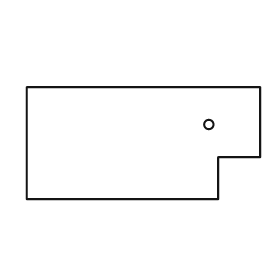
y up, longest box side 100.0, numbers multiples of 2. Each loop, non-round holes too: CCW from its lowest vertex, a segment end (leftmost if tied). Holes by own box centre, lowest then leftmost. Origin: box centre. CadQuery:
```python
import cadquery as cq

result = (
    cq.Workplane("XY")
    .moveTo(-50.0, -24.0)
    .lineTo(32.0, -24.0)
    .lineTo(32.0, -6.0)
    .lineTo(50.0, -6.0)
    .lineTo(50.0, 24.0)
    .lineTo(-50.0, 24.0)
    .close()
    .moveTo(28.0, 8.0)
    .circle(2.0)
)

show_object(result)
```